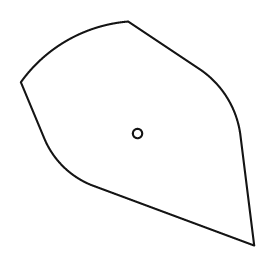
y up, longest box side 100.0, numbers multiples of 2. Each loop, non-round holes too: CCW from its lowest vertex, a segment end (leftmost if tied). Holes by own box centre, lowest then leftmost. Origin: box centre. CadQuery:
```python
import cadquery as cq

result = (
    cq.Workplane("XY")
    .moveTo(50.0, -48.0)
    .lineTo(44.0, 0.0)
    .threePointArc((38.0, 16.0), (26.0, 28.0))
    .lineTo(-4.0, 48.0)
    .threePointArc((-30.0, 40.0), (-50.0, 22.0))
    .lineTo(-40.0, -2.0)
    .threePointArc((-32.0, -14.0), (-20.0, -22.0))
    .close()
    .moveTo(0.0, 0.0)
    .circle(2.0)
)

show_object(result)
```